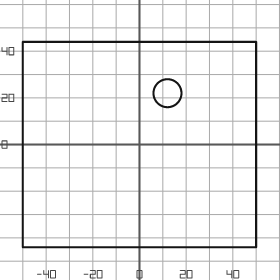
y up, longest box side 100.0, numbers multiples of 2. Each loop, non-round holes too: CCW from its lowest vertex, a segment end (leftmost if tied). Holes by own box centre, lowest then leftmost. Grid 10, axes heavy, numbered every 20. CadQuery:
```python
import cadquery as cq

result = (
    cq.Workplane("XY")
    .moveTo(-50.0, -44.0)
    .lineTo(50.0, -44.0)
    .lineTo(50.0, 44.0)
    .lineTo(-50.0, 44.0)
    .close()
    .moveTo(12.0, 22.0)
    .circle(6.0)
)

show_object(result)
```